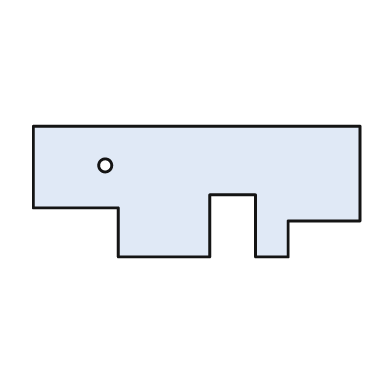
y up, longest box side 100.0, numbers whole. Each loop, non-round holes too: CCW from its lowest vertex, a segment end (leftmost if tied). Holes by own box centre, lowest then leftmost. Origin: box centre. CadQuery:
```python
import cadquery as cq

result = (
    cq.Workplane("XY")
    .moveTo(-24.0, -20.0)
    .lineTo(4.0, -20.0)
    .lineTo(4.0, -1.0)
    .lineTo(18.0, -1.0)
    .lineTo(18.0, -20.0)
    .lineTo(28.0, -20.0)
    .lineTo(28.0, -9.0)
    .lineTo(50.0, -9.0)
    .lineTo(50.0, 20.0)
    .lineTo(-50.0, 20.0)
    .lineTo(-50.0, -5.0)
    .lineTo(-24.0, -5.0)
    .close()
    .moveTo(-28.0, 8.0)
    .circle(2.0)
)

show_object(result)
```